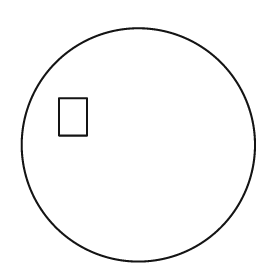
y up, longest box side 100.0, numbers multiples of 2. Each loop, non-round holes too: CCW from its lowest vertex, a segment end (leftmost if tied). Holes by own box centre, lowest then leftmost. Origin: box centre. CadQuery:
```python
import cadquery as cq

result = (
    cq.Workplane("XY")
    .moveTo(0.0, 0.0)
    .circle(50.0)
    .moveTo(-34.0, 4.0)
    .lineTo(-22.0, 4.0)
    .lineTo(-22.0, 20.0)
    .lineTo(-34.0, 20.0)
    .close()
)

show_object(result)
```